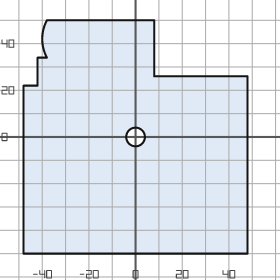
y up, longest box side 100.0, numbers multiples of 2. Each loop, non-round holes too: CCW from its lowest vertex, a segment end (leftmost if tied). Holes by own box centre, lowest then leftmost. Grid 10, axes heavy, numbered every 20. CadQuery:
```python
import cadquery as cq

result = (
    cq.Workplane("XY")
    .moveTo(-48.0, -50.0)
    .lineTo(48.0, -50.0)
    .lineTo(48.0, 26.0)
    .lineTo(8.0, 26.0)
    .lineTo(8.0, 50.0)
    .lineTo(-38.0, 50.0)
    .threePointArc((-40.0, 42.0), (-38.0, 34.0))
    .lineTo(-42.0, 34.0)
    .lineTo(-42.0, 22.0)
    .lineTo(-48.0, 22.0)
    .close()
    .moveTo(0.0, 0.0)
    .circle(4.0)
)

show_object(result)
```